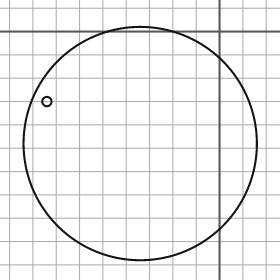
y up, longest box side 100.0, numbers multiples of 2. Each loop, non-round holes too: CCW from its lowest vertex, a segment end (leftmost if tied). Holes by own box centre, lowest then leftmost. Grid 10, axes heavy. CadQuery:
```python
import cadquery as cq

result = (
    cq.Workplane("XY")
    .moveTo(-34.0, -48.0)
    .circle(50.0)
    .moveTo(-74.0, -30.0)
    .circle(2.0)
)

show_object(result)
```